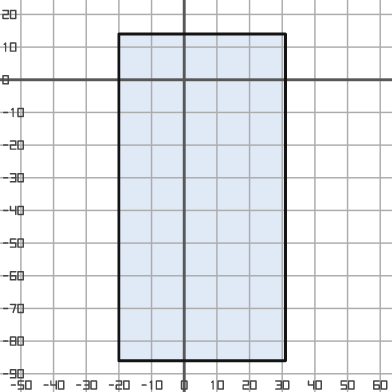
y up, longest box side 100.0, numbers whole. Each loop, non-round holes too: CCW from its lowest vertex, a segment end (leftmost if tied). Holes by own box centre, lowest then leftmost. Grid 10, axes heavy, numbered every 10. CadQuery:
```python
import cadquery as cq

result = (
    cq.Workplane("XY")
    .moveTo(-20.0, -86.0)
    .lineTo(31.0, -86.0)
    .lineTo(31.0, 14.0)
    .lineTo(-20.0, 14.0)
    .close()
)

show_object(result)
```